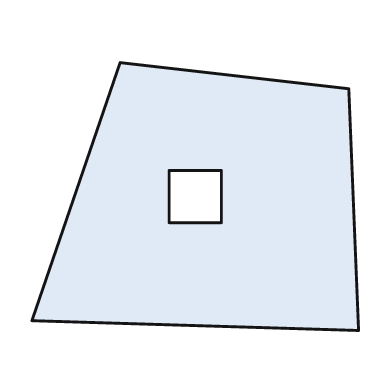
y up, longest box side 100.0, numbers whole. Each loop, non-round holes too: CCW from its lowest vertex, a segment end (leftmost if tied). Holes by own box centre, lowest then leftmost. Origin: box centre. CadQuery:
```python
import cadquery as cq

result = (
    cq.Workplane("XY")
    .moveTo(50.0, -41.0)
    .lineTo(47.0, 33.0)
    .lineTo(-23.0, 41.0)
    .lineTo(-50.0, -38.0)
    .close()
    .moveTo(-8.0, -8.0)
    .lineTo(8.0, -8.0)
    .lineTo(8.0, 8.0)
    .lineTo(-8.0, 8.0)
    .close()
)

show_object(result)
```